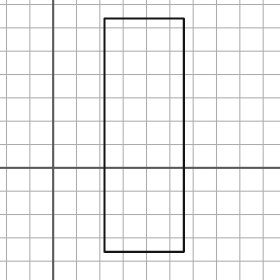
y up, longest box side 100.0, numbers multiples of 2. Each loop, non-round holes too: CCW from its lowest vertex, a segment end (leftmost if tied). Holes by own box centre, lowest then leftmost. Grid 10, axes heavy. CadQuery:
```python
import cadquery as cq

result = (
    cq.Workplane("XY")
    .moveTo(22.0, -36.0)
    .lineTo(56.0, -36.0)
    .lineTo(56.0, 64.0)
    .lineTo(22.0, 64.0)
    .close()
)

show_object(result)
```